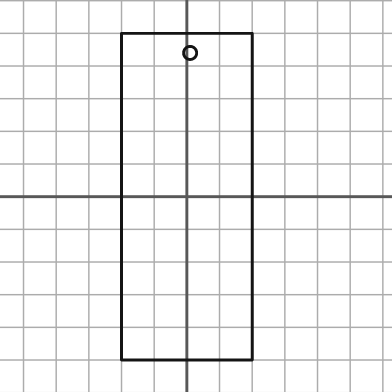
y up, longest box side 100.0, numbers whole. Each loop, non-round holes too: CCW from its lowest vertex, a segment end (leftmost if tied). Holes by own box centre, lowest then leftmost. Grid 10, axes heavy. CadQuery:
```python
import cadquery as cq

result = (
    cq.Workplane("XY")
    .moveTo(-20.0, -50.0)
    .lineTo(20.0, -50.0)
    .lineTo(20.0, 50.0)
    .lineTo(-20.0, 50.0)
    .close()
    .moveTo(1.0, 44.0)
    .circle(2.0)
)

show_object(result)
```